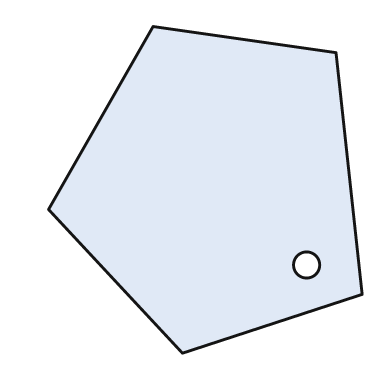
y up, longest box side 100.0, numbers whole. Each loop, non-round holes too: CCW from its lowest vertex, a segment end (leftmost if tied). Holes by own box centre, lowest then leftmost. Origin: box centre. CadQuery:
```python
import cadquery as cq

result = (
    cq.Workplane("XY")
    .moveTo(-7.0, -50.0)
    .lineTo(48.0, -32.0)
    .lineTo(40.0, 42.0)
    .lineTo(-16.0, 50.0)
    .lineTo(-48.0, -6.0)
    .close()
    .moveTo(31.0, -23.0)
    .circle(4.0)
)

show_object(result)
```